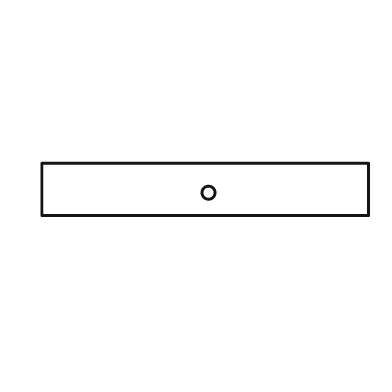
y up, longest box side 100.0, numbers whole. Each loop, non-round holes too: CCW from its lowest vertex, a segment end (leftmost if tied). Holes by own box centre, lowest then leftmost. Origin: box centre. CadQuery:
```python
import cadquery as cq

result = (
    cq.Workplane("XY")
    .moveTo(-50.0, -8.0)
    .lineTo(50.0, -8.0)
    .lineTo(50.0, 8.0)
    .lineTo(-50.0, 8.0)
    .close()
    .moveTo(1.0, -1.0)
    .circle(2.0)
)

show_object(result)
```